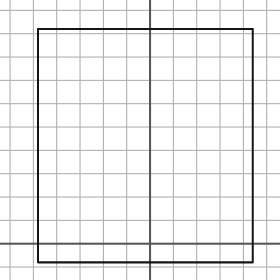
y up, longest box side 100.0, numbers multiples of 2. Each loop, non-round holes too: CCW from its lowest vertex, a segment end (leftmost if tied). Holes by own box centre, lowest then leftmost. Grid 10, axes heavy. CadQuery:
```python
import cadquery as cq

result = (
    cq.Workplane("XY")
    .moveTo(-48.0, -8.0)
    .lineTo(44.0, -8.0)
    .lineTo(44.0, 92.0)
    .lineTo(-48.0, 92.0)
    .close()
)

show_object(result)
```